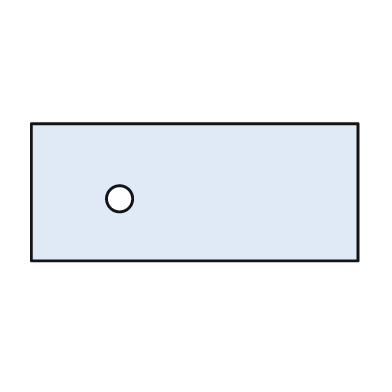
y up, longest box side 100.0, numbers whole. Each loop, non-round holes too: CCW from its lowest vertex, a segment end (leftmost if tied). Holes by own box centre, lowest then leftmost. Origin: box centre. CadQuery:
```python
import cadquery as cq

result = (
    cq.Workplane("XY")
    .moveTo(-50.0, -21.0)
    .lineTo(50.0, -21.0)
    .lineTo(50.0, 21.0)
    .lineTo(-50.0, 21.0)
    .close()
    .moveTo(-23.0, -2.0)
    .circle(4.0)
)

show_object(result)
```